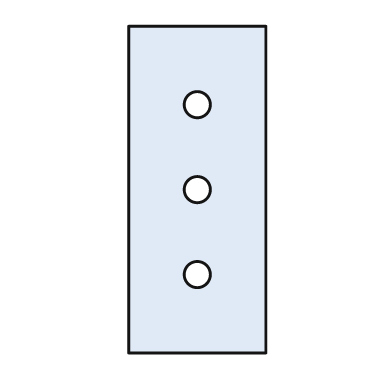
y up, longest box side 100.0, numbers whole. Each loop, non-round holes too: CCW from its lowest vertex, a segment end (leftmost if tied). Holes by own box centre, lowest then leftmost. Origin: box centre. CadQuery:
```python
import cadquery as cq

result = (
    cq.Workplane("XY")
    .moveTo(-21.0, -50.0)
    .lineTo(21.0, -50.0)
    .lineTo(21.0, 50.0)
    .lineTo(-21.0, 50.0)
    .close()
    .moveTo(0.0, -26.0)
    .circle(4.0)
    .moveTo(0.0, 0.0)
    .circle(4.0)
    .moveTo(0.0, 26.0)
    .circle(4.0)
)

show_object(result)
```